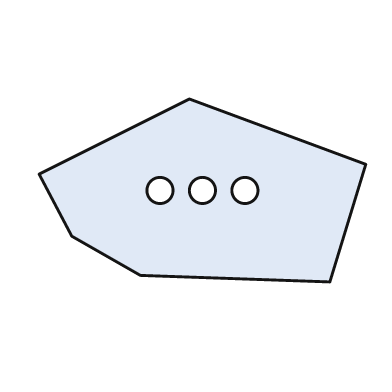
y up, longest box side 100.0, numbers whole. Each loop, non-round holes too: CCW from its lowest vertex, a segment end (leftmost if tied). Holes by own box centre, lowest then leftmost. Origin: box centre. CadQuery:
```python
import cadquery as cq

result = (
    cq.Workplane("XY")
    .moveTo(39.0, -28.0)
    .lineTo(50.0, 8.0)
    .lineTo(-4.0, 28.0)
    .lineTo(-50.0, 5.0)
    .lineTo(-40.0, -14.0)
    .lineTo(-19.0, -26.0)
    .close()
    .moveTo(-13.0, 0.0)
    .circle(4.0)
    .moveTo(0.0, 0.0)
    .circle(4.0)
    .moveTo(13.0, 0.0)
    .circle(4.0)
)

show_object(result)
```